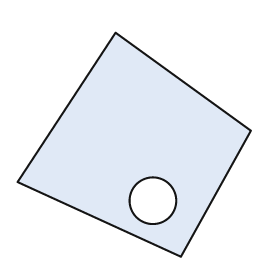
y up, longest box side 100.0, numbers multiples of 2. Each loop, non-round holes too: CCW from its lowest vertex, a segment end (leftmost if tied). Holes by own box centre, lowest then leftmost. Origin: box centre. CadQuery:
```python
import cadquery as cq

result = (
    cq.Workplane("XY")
    .moveTo(20.0, -48.0)
    .lineTo(50.0, 6.0)
    .lineTo(-8.0, 48.0)
    .lineTo(-50.0, -16.0)
    .close()
    .moveTo(8.0, -24.0)
    .circle(10.0)
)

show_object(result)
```